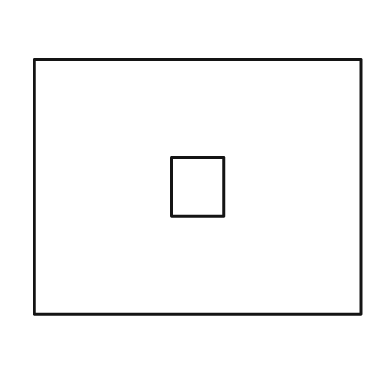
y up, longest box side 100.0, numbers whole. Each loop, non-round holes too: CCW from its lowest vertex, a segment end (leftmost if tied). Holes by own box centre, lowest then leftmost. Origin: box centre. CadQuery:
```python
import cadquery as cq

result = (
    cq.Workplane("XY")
    .moveTo(-50.0, -39.0)
    .lineTo(50.0, -39.0)
    .lineTo(50.0, 39.0)
    .lineTo(-50.0, 39.0)
    .close()
    .moveTo(-8.0, -9.0)
    .lineTo(8.0, -9.0)
    .lineTo(8.0, 9.0)
    .lineTo(-8.0, 9.0)
    .close()
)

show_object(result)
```